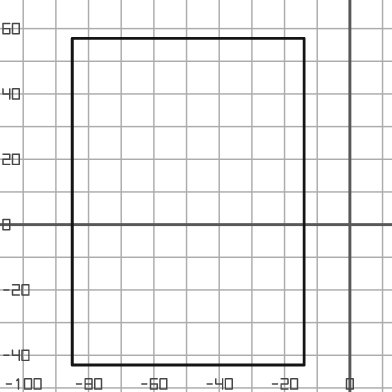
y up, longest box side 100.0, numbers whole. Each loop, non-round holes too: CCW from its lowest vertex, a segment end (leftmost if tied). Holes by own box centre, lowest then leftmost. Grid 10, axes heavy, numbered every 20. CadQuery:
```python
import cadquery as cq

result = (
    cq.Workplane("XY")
    .moveTo(-85.0, -43.0)
    .lineTo(-14.0, -43.0)
    .lineTo(-14.0, 57.0)
    .lineTo(-85.0, 57.0)
    .close()
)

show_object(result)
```